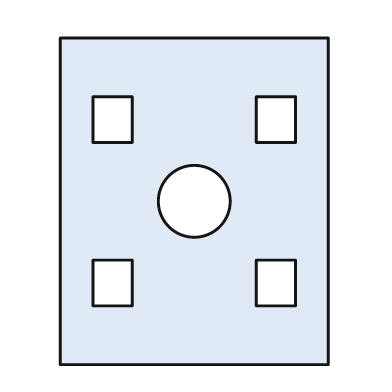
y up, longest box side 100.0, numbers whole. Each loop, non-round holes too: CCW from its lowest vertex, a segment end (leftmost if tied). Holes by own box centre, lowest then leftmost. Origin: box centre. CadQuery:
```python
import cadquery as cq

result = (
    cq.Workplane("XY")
    .moveTo(-41.0, -50.0)
    .lineTo(41.0, -50.0)
    .lineTo(41.0, 50.0)
    .lineTo(-41.0, 50.0)
    .close()
    .moveTo(-31.0, -32.0)
    .lineTo(-19.0, -32.0)
    .lineTo(-19.0, -18.0)
    .lineTo(-31.0, -18.0)
    .close()
    .moveTo(19.0, -32.0)
    .lineTo(31.0, -32.0)
    .lineTo(31.0, -18.0)
    .lineTo(19.0, -18.0)
    .close()
    .moveTo(0.0, 0.0)
    .circle(11.0)
    .moveTo(-31.0, 18.0)
    .lineTo(-19.0, 18.0)
    .lineTo(-19.0, 32.0)
    .lineTo(-31.0, 32.0)
    .close()
    .moveTo(19.0, 18.0)
    .lineTo(31.0, 18.0)
    .lineTo(31.0, 32.0)
    .lineTo(19.0, 32.0)
    .close()
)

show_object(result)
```